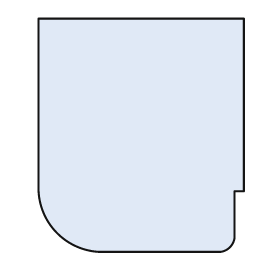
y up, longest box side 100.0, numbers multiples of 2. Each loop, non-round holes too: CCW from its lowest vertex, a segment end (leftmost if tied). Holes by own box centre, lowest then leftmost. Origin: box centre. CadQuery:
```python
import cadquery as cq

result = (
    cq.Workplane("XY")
    .moveTo(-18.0, -50.0)
    .lineTo(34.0, -50.0)
    .threePointArc((38.0, -48.0), (40.0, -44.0))
    .lineTo(40.0, -24.0)
    .lineTo(44.0, -24.0)
    .lineTo(44.0, 50.0)
    .lineTo(-44.0, 50.0)
    .lineTo(-44.0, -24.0)
    .threePointArc((-36.0, -42.0), (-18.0, -50.0))
    .close()
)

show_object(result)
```